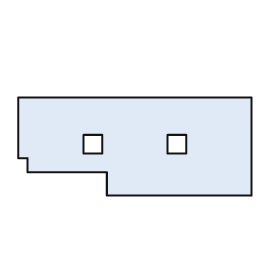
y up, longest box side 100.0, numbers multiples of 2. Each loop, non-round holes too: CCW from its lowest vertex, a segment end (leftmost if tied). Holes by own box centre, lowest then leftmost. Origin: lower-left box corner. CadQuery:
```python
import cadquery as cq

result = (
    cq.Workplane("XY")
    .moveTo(38.0, 0.0)
    .lineTo(100.0, 0.0)
    .lineTo(100.0, 42.0)
    .lineTo(0.0, 42.0)
    .lineTo(0.0, 16.0)
    .lineTo(4.0, 16.0)
    .lineTo(4.0, 10.0)
    .lineTo(38.0, 10.0)
    .close()
    .moveTo(28.0, 18.0)
    .lineTo(36.0, 18.0)
    .lineTo(36.0, 26.0)
    .lineTo(28.0, 26.0)
    .close()
    .moveTo(64.0, 18.0)
    .lineTo(72.0, 18.0)
    .lineTo(72.0, 26.0)
    .lineTo(64.0, 26.0)
    .close()
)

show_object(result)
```